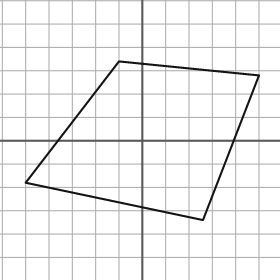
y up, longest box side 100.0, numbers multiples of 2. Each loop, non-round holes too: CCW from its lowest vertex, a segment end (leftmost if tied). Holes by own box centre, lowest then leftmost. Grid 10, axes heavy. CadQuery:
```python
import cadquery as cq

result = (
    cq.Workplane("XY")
    .moveTo(26.0, -34.0)
    .lineTo(50.0, 28.0)
    .lineTo(-10.0, 34.0)
    .lineTo(-50.0, -18.0)
    .close()
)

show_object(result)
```